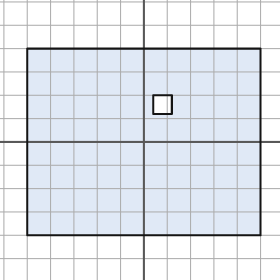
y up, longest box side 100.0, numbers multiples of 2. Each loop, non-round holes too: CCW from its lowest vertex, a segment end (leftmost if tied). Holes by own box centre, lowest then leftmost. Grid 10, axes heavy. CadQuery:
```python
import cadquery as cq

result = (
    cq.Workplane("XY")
    .moveTo(-50.0, -40.0)
    .lineTo(50.0, -40.0)
    .lineTo(50.0, 40.0)
    .lineTo(-50.0, 40.0)
    .close()
    .moveTo(4.0, 12.0)
    .lineTo(12.0, 12.0)
    .lineTo(12.0, 20.0)
    .lineTo(4.0, 20.0)
    .close()
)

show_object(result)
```